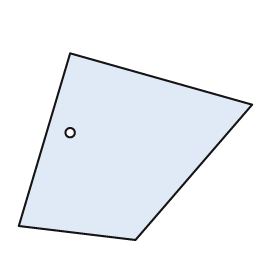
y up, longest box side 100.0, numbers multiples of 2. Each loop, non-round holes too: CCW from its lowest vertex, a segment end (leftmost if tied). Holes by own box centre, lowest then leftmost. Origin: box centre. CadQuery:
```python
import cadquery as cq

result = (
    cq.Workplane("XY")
    .moveTo(0.0, -40.0)
    .lineTo(50.0, 18.0)
    .lineTo(-28.0, 40.0)
    .lineTo(-50.0, -34.0)
    .close()
    .moveTo(-28.0, 6.0)
    .circle(2.0)
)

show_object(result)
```